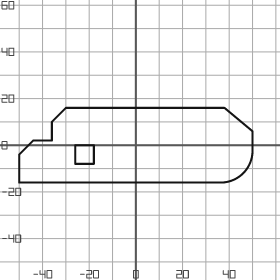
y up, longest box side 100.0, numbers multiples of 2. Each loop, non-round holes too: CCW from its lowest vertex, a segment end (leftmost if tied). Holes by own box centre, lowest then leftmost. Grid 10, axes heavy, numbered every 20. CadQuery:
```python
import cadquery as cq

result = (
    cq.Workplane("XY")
    .moveTo(-50.0, -16.0)
    .lineTo(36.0, -16.0)
    .threePointArc((46.0, -12.0), (50.0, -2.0))
    .lineTo(50.0, 6.0)
    .lineTo(38.0, 16.0)
    .lineTo(-30.0, 16.0)
    .lineTo(-36.0, 10.0)
    .lineTo(-36.0, 2.0)
    .lineTo(-44.0, 2.0)
    .lineTo(-50.0, -4.0)
    .close()
    .moveTo(-26.0, -8.0)
    .lineTo(-18.0, -8.0)
    .lineTo(-18.0, 0.0)
    .lineTo(-26.0, 0.0)
    .close()
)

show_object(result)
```